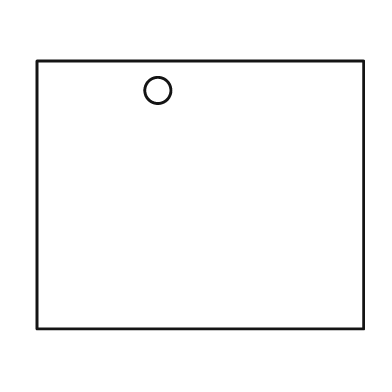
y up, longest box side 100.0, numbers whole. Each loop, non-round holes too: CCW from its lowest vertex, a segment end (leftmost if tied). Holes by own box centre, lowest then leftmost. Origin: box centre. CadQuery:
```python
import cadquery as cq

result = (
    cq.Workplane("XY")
    .moveTo(-50.0, -41.0)
    .lineTo(50.0, -41.0)
    .lineTo(50.0, 41.0)
    .lineTo(-50.0, 41.0)
    .close()
    .moveTo(-13.0, 32.0)
    .circle(4.0)
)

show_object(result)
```